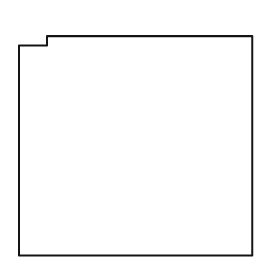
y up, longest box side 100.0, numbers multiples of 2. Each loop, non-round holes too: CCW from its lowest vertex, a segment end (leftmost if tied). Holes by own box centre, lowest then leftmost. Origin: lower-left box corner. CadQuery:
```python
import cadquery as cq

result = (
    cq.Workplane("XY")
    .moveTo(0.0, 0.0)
    .lineTo(100.0, 0.0)
    .lineTo(100.0, 94.0)
    .lineTo(12.0, 94.0)
    .lineTo(12.0, 90.0)
    .lineTo(0.0, 90.0)
    .close()
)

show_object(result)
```